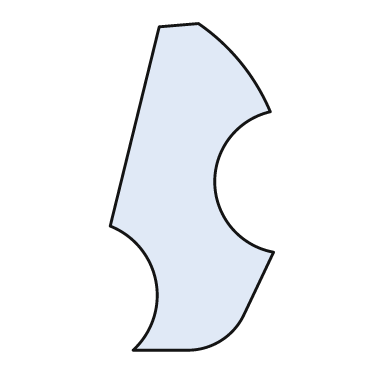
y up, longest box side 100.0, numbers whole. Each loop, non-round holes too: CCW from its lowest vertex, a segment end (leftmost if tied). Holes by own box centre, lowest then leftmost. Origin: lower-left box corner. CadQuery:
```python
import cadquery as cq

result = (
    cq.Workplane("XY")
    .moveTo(7.0, 0.0)
    .lineTo(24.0, 0.0)
    .threePointArc((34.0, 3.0), (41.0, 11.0))
    .lineTo(50.0, 30.0)
    .threePointArc((32.0, 51.0), (49.0, 73.0))
    .threePointArc((40.0, 88.0), (27.0, 100.0))
    .lineTo(15.0, 99.0)
    .lineTo(0.0, 38.0)
    .threePointArc((14.0, 21.0), (7.0, 0.0))
    .close()
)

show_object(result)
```